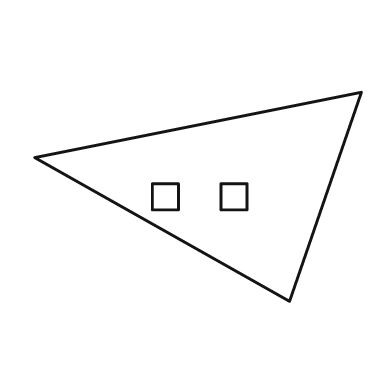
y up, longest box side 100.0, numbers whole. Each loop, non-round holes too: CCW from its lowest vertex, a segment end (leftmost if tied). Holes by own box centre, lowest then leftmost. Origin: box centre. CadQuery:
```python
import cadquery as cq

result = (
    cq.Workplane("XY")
    .moveTo(28.0, -32.0)
    .lineTo(50.0, 32.0)
    .lineTo(-50.0, 12.0)
    .close()
    .moveTo(-14.0, -4.0)
    .lineTo(-6.0, -4.0)
    .lineTo(-6.0, 4.0)
    .lineTo(-14.0, 4.0)
    .close()
    .moveTo(7.0, -4.0)
    .lineTo(15.0, -4.0)
    .lineTo(15.0, 4.0)
    .lineTo(7.0, 4.0)
    .close()
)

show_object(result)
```